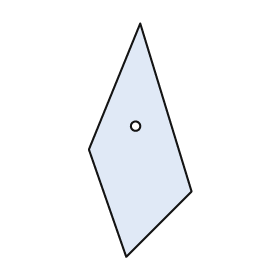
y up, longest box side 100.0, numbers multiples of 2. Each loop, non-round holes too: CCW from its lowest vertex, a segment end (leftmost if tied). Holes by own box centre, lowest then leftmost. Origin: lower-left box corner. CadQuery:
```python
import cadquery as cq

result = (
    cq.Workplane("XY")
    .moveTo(16.0, 0.0)
    .lineTo(44.0, 28.0)
    .lineTo(22.0, 100.0)
    .lineTo(0.0, 46.0)
    .close()
    .moveTo(20.0, 56.0)
    .circle(2.0)
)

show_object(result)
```